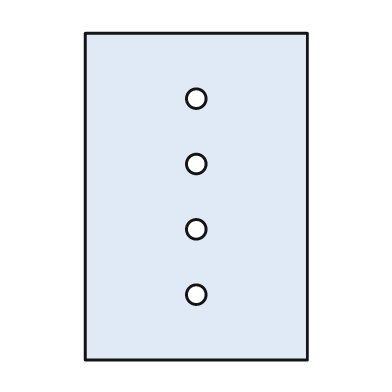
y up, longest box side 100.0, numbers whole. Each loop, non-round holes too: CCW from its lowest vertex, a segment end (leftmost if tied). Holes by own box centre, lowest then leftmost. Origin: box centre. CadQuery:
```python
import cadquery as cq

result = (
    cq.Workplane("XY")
    .moveTo(-34.0, -50.0)
    .lineTo(34.0, -50.0)
    .lineTo(34.0, 50.0)
    .lineTo(-34.0, 50.0)
    .close()
    .moveTo(0.0, -30.0)
    .circle(3.0)
    .moveTo(0.0, -10.0)
    .circle(3.0)
    .moveTo(0.0, 10.0)
    .circle(3.0)
    .moveTo(0.0, 30.0)
    .circle(3.0)
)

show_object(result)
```